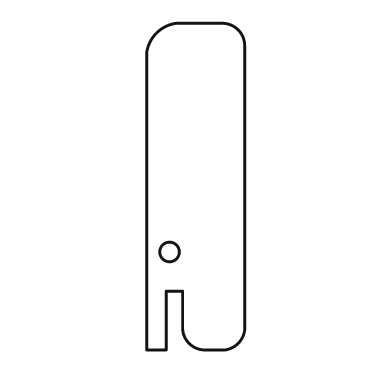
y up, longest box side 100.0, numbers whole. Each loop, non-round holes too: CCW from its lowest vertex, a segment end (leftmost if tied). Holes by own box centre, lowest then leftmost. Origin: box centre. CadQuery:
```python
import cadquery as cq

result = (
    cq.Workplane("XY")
    .moveTo(-15.0, -50.0)
    .lineTo(-9.0, -50.0)
    .lineTo(-9.0, -32.0)
    .lineTo(-4.0, -32.0)
    .lineTo(-4.0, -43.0)
    .threePointArc((-2.0, -48.0), (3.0, -50.0))
    .lineTo(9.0, -50.0)
    .threePointArc((13.0, -48.0), (15.0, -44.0))
    .lineTo(15.0, 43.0)
    .threePointArc((13.0, 48.0), (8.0, 50.0))
    .lineTo(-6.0, 50.0)
    .threePointArc((-12.0, 47.0), (-15.0, 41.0))
    .close()
    .moveTo(-8.0, -20.0)
    .circle(3.0)
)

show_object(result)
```